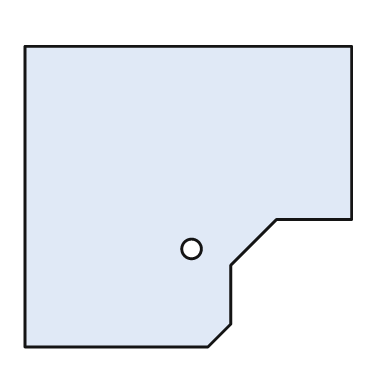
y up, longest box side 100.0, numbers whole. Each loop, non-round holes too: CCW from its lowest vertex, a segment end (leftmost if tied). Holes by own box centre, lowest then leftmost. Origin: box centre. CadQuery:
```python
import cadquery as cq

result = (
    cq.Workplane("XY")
    .moveTo(-50.0, -46.0)
    .lineTo(6.0, -46.0)
    .lineTo(13.0, -39.0)
    .lineTo(13.0, -21.0)
    .lineTo(27.0, -7.0)
    .lineTo(50.0, -7.0)
    .lineTo(50.0, 46.0)
    .lineTo(-50.0, 46.0)
    .close()
    .moveTo(1.0, -16.0)
    .circle(3.0)
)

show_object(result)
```